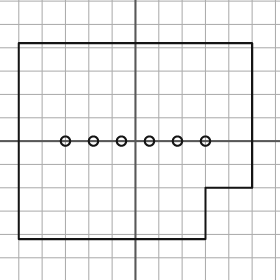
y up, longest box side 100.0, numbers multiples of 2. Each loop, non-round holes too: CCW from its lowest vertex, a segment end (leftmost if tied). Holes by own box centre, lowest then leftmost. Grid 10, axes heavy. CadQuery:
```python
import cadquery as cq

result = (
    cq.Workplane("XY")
    .moveTo(-50.0, -42.0)
    .lineTo(30.0, -42.0)
    .lineTo(30.0, -20.0)
    .lineTo(50.0, -20.0)
    .lineTo(50.0, 42.0)
    .lineTo(-50.0, 42.0)
    .close()
    .moveTo(-30.0, 0.0)
    .circle(2.0)
    .moveTo(-18.0, 0.0)
    .circle(2.0)
    .moveTo(-6.0, 0.0)
    .circle(2.0)
    .moveTo(6.0, 0.0)
    .circle(2.0)
    .moveTo(18.0, 0.0)
    .circle(2.0)
    .moveTo(30.0, 0.0)
    .circle(2.0)
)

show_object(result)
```